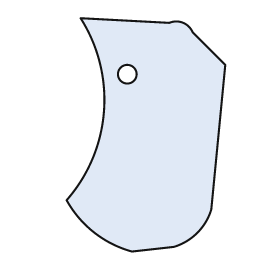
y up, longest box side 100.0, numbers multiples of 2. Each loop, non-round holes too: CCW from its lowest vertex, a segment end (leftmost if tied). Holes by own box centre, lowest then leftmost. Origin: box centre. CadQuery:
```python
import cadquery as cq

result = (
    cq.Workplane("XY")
    .moveTo(-6.0, -50.0)
    .lineTo(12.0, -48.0)
    .threePointArc((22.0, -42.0), (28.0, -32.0))
    .lineTo(34.0, 30.0)
    .lineTo(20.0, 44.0)
    .threePointArc((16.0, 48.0), (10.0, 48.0))
    .lineTo(-28.0, 50.0)
    .threePointArc((-18.0, 10.0), (-34.0, -28.0))
    .threePointArc((-22.0, -42.0), (-6.0, -50.0))
    .close()
    .moveTo(-8.0, 26.0)
    .circle(4.0)
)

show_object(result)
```